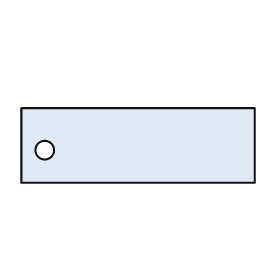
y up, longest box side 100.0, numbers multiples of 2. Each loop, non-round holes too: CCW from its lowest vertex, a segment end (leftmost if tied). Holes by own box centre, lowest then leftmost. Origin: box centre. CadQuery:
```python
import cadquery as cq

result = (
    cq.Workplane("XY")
    .moveTo(-50.0, -16.0)
    .lineTo(50.0, -16.0)
    .lineTo(50.0, 16.0)
    .lineTo(-50.0, 16.0)
    .close()
    .moveTo(-40.0, -2.0)
    .circle(4.0)
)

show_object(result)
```